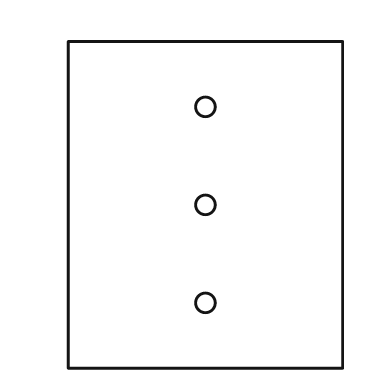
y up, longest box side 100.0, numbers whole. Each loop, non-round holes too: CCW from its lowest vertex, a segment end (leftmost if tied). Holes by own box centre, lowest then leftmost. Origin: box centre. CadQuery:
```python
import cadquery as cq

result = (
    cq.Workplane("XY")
    .moveTo(-42.0, -50.0)
    .lineTo(42.0, -50.0)
    .lineTo(42.0, 50.0)
    .lineTo(-42.0, 50.0)
    .close()
    .moveTo(0.0, -30.0)
    .circle(3.0)
    .moveTo(0.0, 0.0)
    .circle(3.0)
    .moveTo(0.0, 30.0)
    .circle(3.0)
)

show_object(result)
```